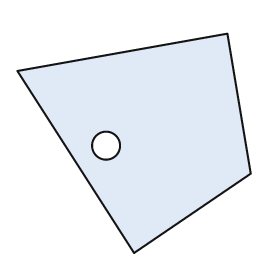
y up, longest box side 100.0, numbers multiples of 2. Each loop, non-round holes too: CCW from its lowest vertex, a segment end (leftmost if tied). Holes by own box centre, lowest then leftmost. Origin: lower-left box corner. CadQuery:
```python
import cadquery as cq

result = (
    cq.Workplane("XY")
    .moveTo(50.0, 0.0)
    .lineTo(100.0, 34.0)
    .lineTo(90.0, 94.0)
    .lineTo(0.0, 78.0)
    .close()
    .moveTo(38.0, 46.0)
    .circle(6.0)
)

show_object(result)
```